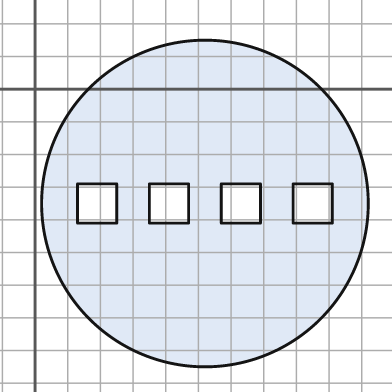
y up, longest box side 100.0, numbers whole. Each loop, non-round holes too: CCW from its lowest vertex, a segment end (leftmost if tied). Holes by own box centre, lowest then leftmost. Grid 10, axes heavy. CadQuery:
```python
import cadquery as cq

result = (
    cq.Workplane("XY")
    .moveTo(52.0, -35.0)
    .circle(50.0)
    .moveTo(13.0, -41.0)
    .lineTo(25.0, -41.0)
    .lineTo(25.0, -29.0)
    .lineTo(13.0, -29.0)
    .close()
    .moveTo(35.0, -41.0)
    .lineTo(47.0, -41.0)
    .lineTo(47.0, -29.0)
    .lineTo(35.0, -29.0)
    .close()
    .moveTo(57.0, -41.0)
    .lineTo(69.0, -41.0)
    .lineTo(69.0, -29.0)
    .lineTo(57.0, -29.0)
    .close()
    .moveTo(79.0, -41.0)
    .lineTo(91.0, -41.0)
    .lineTo(91.0, -29.0)
    .lineTo(79.0, -29.0)
    .close()
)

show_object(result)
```